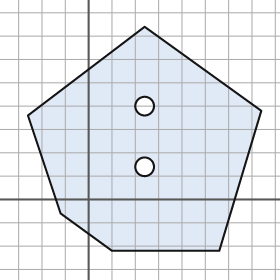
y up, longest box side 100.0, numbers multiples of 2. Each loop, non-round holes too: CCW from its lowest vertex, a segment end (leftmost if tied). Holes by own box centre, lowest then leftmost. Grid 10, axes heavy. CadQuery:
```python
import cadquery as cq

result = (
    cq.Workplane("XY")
    .moveTo(10.0, -22.0)
    .lineTo(56.0, -22.0)
    .lineTo(74.0, 38.0)
    .lineTo(24.0, 74.0)
    .lineTo(-26.0, 36.0)
    .lineTo(-12.0, -6.0)
    .close()
    .moveTo(24.0, 14.0)
    .circle(4.0)
    .moveTo(24.0, 40.0)
    .circle(4.0)
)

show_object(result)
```